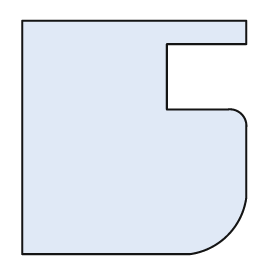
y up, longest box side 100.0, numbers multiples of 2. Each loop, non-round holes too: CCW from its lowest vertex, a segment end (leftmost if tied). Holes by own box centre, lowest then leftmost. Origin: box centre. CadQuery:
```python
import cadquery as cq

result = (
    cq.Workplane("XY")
    .moveTo(-48.0, -50.0)
    .lineTo(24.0, -50.0)
    .threePointArc((40.0, -42.0), (48.0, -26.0))
    .lineTo(48.0, 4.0)
    .threePointArc((46.0, 10.0), (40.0, 12.0))
    .lineTo(14.0, 12.0)
    .lineTo(14.0, 40.0)
    .lineTo(48.0, 40.0)
    .lineTo(48.0, 50.0)
    .lineTo(-48.0, 50.0)
    .close()
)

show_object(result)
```